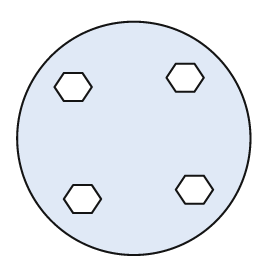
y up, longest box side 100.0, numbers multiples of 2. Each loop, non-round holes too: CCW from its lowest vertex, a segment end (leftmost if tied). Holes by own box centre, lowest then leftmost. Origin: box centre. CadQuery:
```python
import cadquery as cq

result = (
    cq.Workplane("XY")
    .moveTo(0.0, 0.0)
    .circle(50.0)
    .moveTo(-26.0, -32.0)
    .lineTo(-18.0, -32.0)
    .lineTo(-14.0, -26.0)
    .lineTo(-18.0, -20.0)
    .lineTo(-26.0, -20.0)
    .lineTo(-30.0, -26.0)
    .close()
    .moveTo(22.0, -28.0)
    .lineTo(30.0, -28.0)
    .lineTo(34.0, -22.0)
    .lineTo(30.0, -16.0)
    .lineTo(22.0, -16.0)
    .lineTo(18.0, -22.0)
    .close()
    .moveTo(-30.0, 16.0)
    .lineTo(-22.0, 16.0)
    .lineTo(-18.0, 22.0)
    .lineTo(-22.0, 28.0)
    .lineTo(-30.0, 28.0)
    .lineTo(-34.0, 22.0)
    .close()
    .moveTo(18.0, 20.0)
    .lineTo(26.0, 20.0)
    .lineTo(30.0, 26.0)
    .lineTo(26.0, 32.0)
    .lineTo(18.0, 32.0)
    .lineTo(14.0, 26.0)
    .close()
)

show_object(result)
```